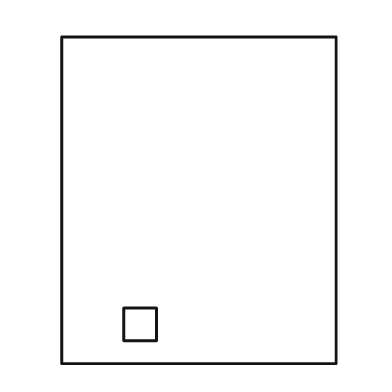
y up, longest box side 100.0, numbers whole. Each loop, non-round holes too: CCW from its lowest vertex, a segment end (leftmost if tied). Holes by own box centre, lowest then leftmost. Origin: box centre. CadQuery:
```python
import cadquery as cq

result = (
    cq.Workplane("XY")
    .moveTo(-42.0, -50.0)
    .lineTo(42.0, -50.0)
    .lineTo(42.0, 50.0)
    .lineTo(-42.0, 50.0)
    .close()
    .moveTo(-23.0, -43.0)
    .lineTo(-13.0, -43.0)
    .lineTo(-13.0, -33.0)
    .lineTo(-23.0, -33.0)
    .close()
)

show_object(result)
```